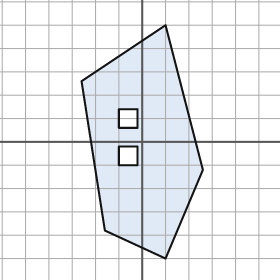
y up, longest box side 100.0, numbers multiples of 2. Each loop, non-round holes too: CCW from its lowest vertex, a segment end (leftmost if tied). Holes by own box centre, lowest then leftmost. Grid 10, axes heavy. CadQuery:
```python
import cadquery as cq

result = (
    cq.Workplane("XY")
    .moveTo(10.0, -50.0)
    .lineTo(26.0, -12.0)
    .lineTo(10.0, 50.0)
    .lineTo(-26.0, 26.0)
    .lineTo(-16.0, -38.0)
    .close()
    .moveTo(-10.0, -10.0)
    .lineTo(-2.0, -10.0)
    .lineTo(-2.0, -2.0)
    .lineTo(-10.0, -2.0)
    .close()
    .moveTo(-10.0, 6.0)
    .lineTo(-2.0, 6.0)
    .lineTo(-2.0, 14.0)
    .lineTo(-10.0, 14.0)
    .close()
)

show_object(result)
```